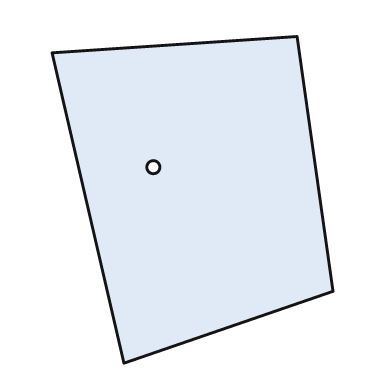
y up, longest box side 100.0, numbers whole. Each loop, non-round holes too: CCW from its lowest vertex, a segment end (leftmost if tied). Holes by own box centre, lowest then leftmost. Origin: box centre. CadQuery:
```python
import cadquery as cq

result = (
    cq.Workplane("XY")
    .moveTo(-21.0, -50.0)
    .lineTo(43.0, -28.0)
    .lineTo(32.0, 50.0)
    .lineTo(-43.0, 45.0)
    .close()
    .moveTo(-12.0, 10.0)
    .circle(2.0)
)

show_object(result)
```